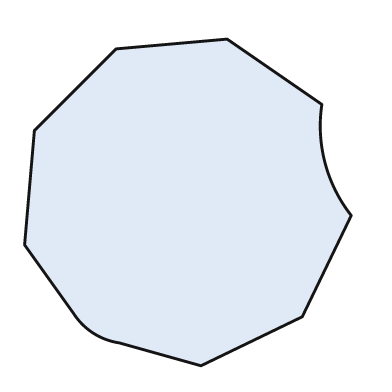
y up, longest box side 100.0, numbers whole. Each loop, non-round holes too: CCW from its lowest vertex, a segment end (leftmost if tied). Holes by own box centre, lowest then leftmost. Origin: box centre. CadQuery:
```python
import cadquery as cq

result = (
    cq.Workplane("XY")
    .moveTo(4.0, -50.0)
    .lineTo(35.0, -35.0)
    .lineTo(50.0, -4.0)
    .threePointArc((42.0, 12.0), (41.0, 30.0))
    .lineTo(12.0, 50.0)
    .lineTo(-22.0, 47.0)
    .lineTo(-47.0, 22.0)
    .lineTo(-50.0, -13.0)
    .lineTo(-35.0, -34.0)
    .threePointArc((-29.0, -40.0), (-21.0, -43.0))
    .close()
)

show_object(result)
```